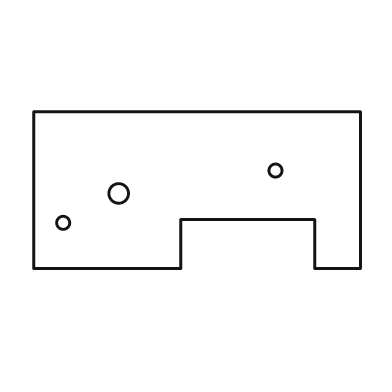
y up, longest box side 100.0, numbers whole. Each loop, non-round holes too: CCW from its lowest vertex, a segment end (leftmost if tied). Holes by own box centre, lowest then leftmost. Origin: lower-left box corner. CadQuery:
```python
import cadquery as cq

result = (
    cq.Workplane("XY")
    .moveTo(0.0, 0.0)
    .lineTo(45.0, 0.0)
    .lineTo(45.0, 15.0)
    .lineTo(86.0, 15.0)
    .lineTo(86.0, 0.0)
    .lineTo(100.0, 0.0)
    .lineTo(100.0, 48.0)
    .lineTo(0.0, 48.0)
    .close()
    .moveTo(9.0, 14.0)
    .circle(2.0)
    .moveTo(26.0, 23.0)
    .circle(3.0)
    .moveTo(74.0, 30.0)
    .circle(2.0)
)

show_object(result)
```